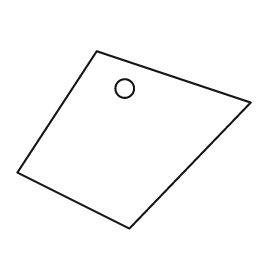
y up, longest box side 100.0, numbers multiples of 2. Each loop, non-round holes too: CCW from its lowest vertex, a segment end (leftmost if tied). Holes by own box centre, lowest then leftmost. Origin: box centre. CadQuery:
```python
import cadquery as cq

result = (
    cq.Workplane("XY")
    .moveTo(-2.0, -38.0)
    .lineTo(50.0, 16.0)
    .lineTo(-16.0, 38.0)
    .lineTo(-50.0, -14.0)
    .close()
    .moveTo(-4.0, 22.0)
    .circle(4.0)
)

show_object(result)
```